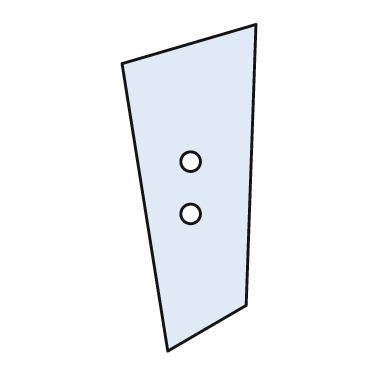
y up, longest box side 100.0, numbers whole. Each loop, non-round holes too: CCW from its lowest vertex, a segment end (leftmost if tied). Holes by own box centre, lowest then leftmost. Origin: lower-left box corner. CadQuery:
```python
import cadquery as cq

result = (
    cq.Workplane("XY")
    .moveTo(14.0, 0.0)
    .lineTo(38.0, 14.0)
    .lineTo(41.0, 100.0)
    .lineTo(0.0, 88.0)
    .close()
    .moveTo(21.0, 42.0)
    .circle(3.0)
    .moveTo(21.0, 58.0)
    .circle(3.0)
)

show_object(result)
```